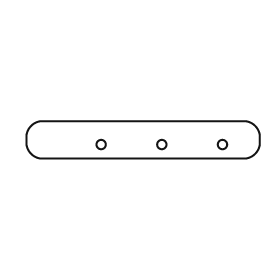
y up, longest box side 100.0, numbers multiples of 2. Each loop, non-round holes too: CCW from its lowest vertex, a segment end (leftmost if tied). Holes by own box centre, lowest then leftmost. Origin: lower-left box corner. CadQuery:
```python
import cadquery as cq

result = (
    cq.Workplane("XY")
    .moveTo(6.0, 0.0)
    .lineTo(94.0, 0.0)
    .threePointArc((98.0, 2.0), (100.0, 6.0))
    .lineTo(100.0, 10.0)
    .threePointArc((98.0, 14.0), (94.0, 16.0))
    .lineTo(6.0, 16.0)
    .threePointArc((2.0, 14.0), (0.0, 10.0))
    .lineTo(0.0, 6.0)
    .threePointArc((2.0, 2.0), (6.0, 0.0))
    .close()
    .moveTo(32.0, 6.0)
    .circle(2.0)
    .moveTo(58.0, 6.0)
    .circle(2.0)
    .moveTo(84.0, 6.0)
    .circle(2.0)
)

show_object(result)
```